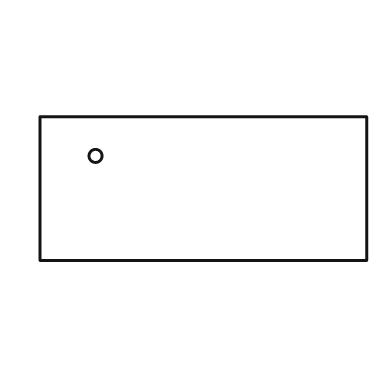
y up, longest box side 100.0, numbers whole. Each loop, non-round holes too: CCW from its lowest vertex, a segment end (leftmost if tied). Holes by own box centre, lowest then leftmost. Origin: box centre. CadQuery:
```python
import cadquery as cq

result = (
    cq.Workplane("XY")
    .moveTo(-50.0, -22.0)
    .lineTo(50.0, -22.0)
    .lineTo(50.0, 22.0)
    .lineTo(-50.0, 22.0)
    .close()
    .moveTo(-33.0, 10.0)
    .circle(2.0)
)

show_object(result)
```